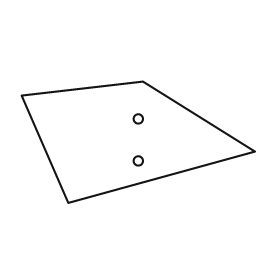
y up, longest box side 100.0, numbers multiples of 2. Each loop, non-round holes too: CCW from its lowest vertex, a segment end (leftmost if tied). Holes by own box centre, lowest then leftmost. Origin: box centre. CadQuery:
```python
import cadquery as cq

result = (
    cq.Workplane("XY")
    .moveTo(-30.0, -26.0)
    .lineTo(50.0, -4.0)
    .lineTo(2.0, 26.0)
    .lineTo(-50.0, 20.0)
    .close()
    .moveTo(0.0, -8.0)
    .circle(2.0)
    .moveTo(0.0, 10.0)
    .circle(2.0)
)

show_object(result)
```